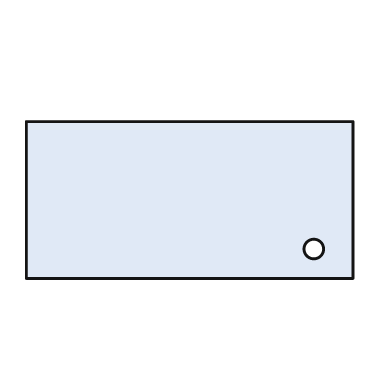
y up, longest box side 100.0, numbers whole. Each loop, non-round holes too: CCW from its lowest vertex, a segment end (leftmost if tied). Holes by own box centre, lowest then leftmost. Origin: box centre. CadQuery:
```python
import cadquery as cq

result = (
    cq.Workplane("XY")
    .moveTo(-50.0, -24.0)
    .lineTo(50.0, -24.0)
    .lineTo(50.0, 24.0)
    .lineTo(-50.0, 24.0)
    .close()
    .moveTo(38.0, -15.0)
    .circle(3.0)
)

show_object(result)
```